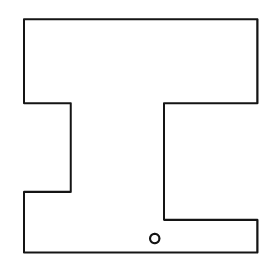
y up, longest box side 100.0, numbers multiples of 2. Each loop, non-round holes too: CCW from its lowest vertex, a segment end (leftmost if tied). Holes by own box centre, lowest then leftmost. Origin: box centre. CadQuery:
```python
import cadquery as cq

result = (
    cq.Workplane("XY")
    .moveTo(-50.0, -50.0)
    .lineTo(50.0, -50.0)
    .lineTo(50.0, -36.0)
    .lineTo(10.0, -36.0)
    .lineTo(10.0, 14.0)
    .lineTo(50.0, 14.0)
    .lineTo(50.0, 50.0)
    .lineTo(-50.0, 50.0)
    .lineTo(-50.0, 14.0)
    .lineTo(-30.0, 14.0)
    .lineTo(-30.0, -24.0)
    .lineTo(-50.0, -24.0)
    .close()
    .moveTo(6.0, -44.0)
    .circle(2.0)
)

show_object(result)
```